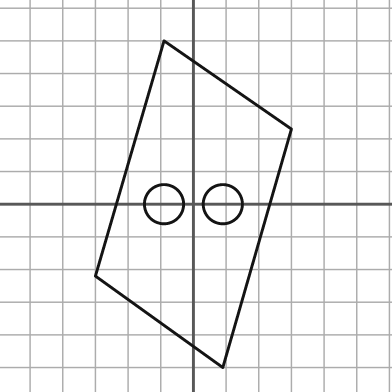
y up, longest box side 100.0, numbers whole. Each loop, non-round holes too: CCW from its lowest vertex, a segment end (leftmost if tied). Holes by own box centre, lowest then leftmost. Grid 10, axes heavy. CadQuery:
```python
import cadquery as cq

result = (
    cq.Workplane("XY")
    .moveTo(9.0, -50.0)
    .lineTo(30.0, 23.0)
    .lineTo(-9.0, 50.0)
    .lineTo(-30.0, -22.0)
    .close()
    .moveTo(-9.0, 0.0)
    .circle(6.0)
    .moveTo(9.0, 0.0)
    .circle(6.0)
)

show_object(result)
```